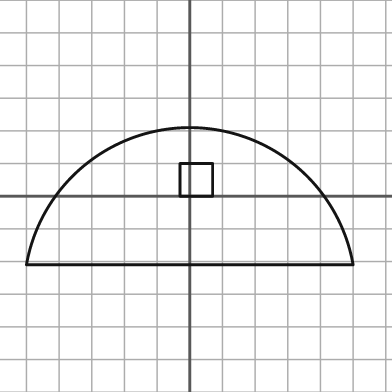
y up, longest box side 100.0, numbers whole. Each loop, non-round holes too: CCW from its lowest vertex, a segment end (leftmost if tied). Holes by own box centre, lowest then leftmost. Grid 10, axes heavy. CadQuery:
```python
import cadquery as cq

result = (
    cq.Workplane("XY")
    .moveTo(-50.0, -21.0)
    .lineTo(50.0, -21.0)
    .threePointArc((0.0, 21.0), (-50.0, -21.0))
    .close()
    .moveTo(-3.0, 0.0)
    .lineTo(7.0, 0.0)
    .lineTo(7.0, 10.0)
    .lineTo(-3.0, 10.0)
    .close()
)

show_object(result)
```